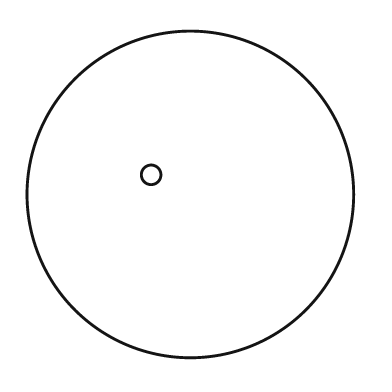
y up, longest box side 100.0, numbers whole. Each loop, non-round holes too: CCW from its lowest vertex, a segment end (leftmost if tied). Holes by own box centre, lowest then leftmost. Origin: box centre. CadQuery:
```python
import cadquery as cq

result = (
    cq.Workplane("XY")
    .moveTo(0.0, 0.0)
    .circle(50.0)
    .moveTo(-12.0, 6.0)
    .circle(3.0)
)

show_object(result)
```